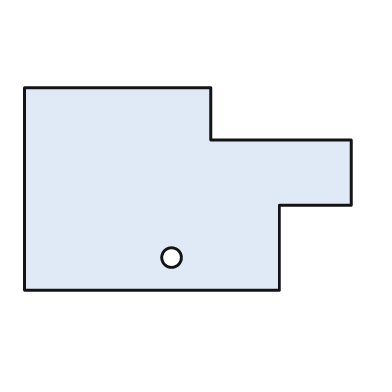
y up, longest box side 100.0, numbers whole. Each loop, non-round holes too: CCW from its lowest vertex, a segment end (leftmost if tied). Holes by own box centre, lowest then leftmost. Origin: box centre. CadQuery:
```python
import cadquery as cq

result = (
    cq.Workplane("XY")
    .moveTo(-50.0, -31.0)
    .lineTo(28.0, -31.0)
    .lineTo(28.0, -5.0)
    .lineTo(50.0, -5.0)
    .lineTo(50.0, 15.0)
    .lineTo(7.0, 15.0)
    .lineTo(7.0, 31.0)
    .lineTo(-50.0, 31.0)
    .close()
    .moveTo(-5.0, -21.0)
    .circle(3.0)
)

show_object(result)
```